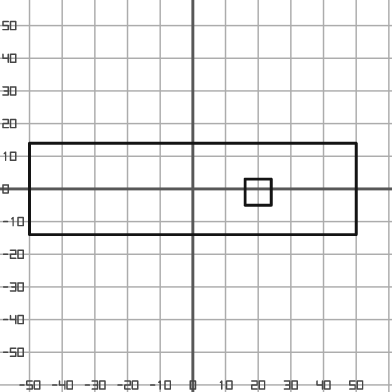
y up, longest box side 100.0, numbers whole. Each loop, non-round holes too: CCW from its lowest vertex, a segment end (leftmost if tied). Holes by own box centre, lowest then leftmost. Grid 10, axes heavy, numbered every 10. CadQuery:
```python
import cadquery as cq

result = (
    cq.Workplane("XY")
    .moveTo(-50.0, -14.0)
    .lineTo(50.0, -14.0)
    .lineTo(50.0, 14.0)
    .lineTo(-50.0, 14.0)
    .close()
    .moveTo(16.0, -5.0)
    .lineTo(24.0, -5.0)
    .lineTo(24.0, 3.0)
    .lineTo(16.0, 3.0)
    .close()
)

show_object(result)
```